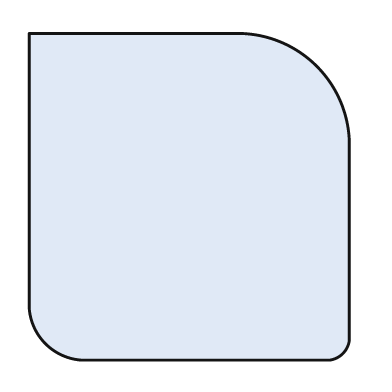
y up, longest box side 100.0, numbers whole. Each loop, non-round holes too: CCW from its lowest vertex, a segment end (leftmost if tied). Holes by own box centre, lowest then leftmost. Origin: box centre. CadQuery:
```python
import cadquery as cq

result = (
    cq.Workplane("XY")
    .moveTo(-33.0, -50.0)
    .lineTo(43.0, -50.0)
    .threePointArc((47.0, -48.0), (49.0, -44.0))
    .lineTo(49.0, 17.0)
    .threePointArc((39.0, 40.0), (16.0, 50.0))
    .lineTo(-49.0, 50.0)
    .lineTo(-49.0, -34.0)
    .threePointArc((-44.0, -45.0), (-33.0, -50.0))
    .close()
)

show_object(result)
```